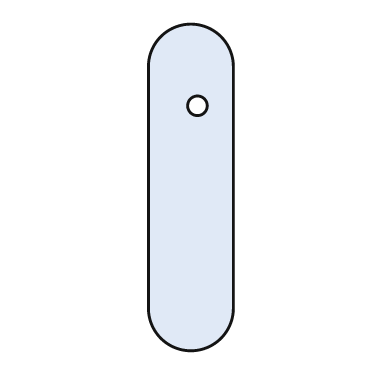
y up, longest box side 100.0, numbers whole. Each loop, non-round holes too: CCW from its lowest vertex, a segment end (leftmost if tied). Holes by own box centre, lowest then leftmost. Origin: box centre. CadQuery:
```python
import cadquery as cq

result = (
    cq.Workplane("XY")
    .moveTo(-13.0, -37.0)
    .threePointArc((0.0, -50.0), (13.0, -37.0))
    .lineTo(13.0, 37.0)
    .threePointArc((0.0, 50.0), (-13.0, 37.0))
    .close()
    .moveTo(2.0, 25.0)
    .circle(3.0)
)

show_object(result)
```